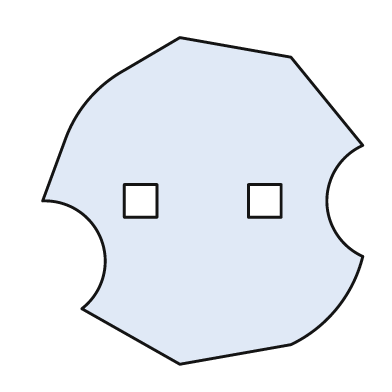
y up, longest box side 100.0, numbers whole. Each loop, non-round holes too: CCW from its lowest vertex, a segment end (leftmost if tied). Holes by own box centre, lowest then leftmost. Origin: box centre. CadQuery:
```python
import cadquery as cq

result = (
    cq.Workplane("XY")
    .moveTo(-7.0, -50.0)
    .lineTo(27.0, -44.0)
    .threePointArc((41.0, -33.0), (49.0, -17.0))
    .threePointArc((38.0, 0.0), (49.0, 17.0))
    .lineTo(27.0, 44.0)
    .lineTo(-7.0, 50.0)
    .lineTo(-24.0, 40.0)
    .threePointArc((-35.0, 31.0), (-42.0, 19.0))
    .lineTo(-49.0, 0.0)
    .threePointArc((-31.0, -12.0), (-37.0, -33.0))
    .close()
    .moveTo(-24.0, -5.0)
    .lineTo(-14.0, -5.0)
    .lineTo(-14.0, 5.0)
    .lineTo(-24.0, 5.0)
    .close()
    .moveTo(14.0, -5.0)
    .lineTo(24.0, -5.0)
    .lineTo(24.0, 5.0)
    .lineTo(14.0, 5.0)
    .close()
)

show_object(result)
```